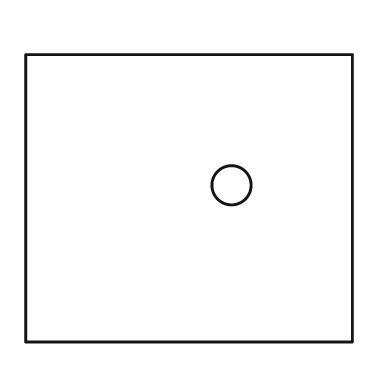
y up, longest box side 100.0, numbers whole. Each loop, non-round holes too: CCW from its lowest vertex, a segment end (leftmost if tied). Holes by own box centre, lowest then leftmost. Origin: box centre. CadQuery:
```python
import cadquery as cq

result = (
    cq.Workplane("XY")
    .moveTo(-50.0, -44.0)
    .lineTo(50.0, -44.0)
    .lineTo(50.0, 44.0)
    .lineTo(-50.0, 44.0)
    .close()
    .moveTo(13.0, 4.0)
    .circle(6.0)
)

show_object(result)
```